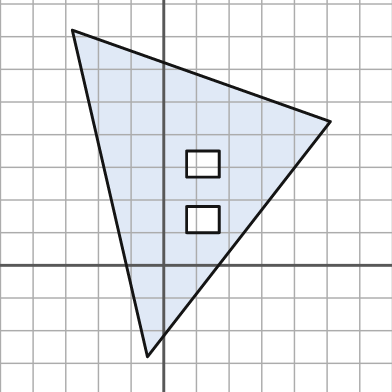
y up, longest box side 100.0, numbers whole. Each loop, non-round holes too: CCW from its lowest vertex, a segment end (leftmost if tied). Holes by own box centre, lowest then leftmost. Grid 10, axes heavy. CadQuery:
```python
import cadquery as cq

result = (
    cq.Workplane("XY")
    .moveTo(-5.0, -28.0)
    .lineTo(51.0, 44.0)
    .lineTo(-28.0, 72.0)
    .close()
    .moveTo(7.0, 10.0)
    .lineTo(17.0, 10.0)
    .lineTo(17.0, 18.0)
    .lineTo(7.0, 18.0)
    .close()
    .moveTo(7.0, 27.0)
    .lineTo(17.0, 27.0)
    .lineTo(17.0, 35.0)
    .lineTo(7.0, 35.0)
    .close()
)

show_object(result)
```